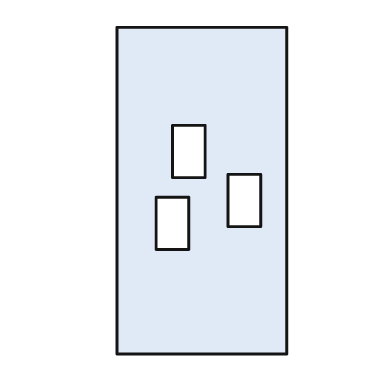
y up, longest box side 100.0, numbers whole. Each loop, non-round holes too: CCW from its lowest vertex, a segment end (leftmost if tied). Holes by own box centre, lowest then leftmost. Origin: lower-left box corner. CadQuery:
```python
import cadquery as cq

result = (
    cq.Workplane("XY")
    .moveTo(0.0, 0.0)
    .lineTo(52.0, 0.0)
    .lineTo(52.0, 100.0)
    .lineTo(0.0, 100.0)
    .close()
    .moveTo(12.0, 32.0)
    .lineTo(22.0, 32.0)
    .lineTo(22.0, 48.0)
    .lineTo(12.0, 48.0)
    .close()
    .moveTo(34.0, 39.0)
    .lineTo(44.0, 39.0)
    .lineTo(44.0, 55.0)
    .lineTo(34.0, 55.0)
    .close()
    .moveTo(17.0, 54.0)
    .lineTo(27.0, 54.0)
    .lineTo(27.0, 70.0)
    .lineTo(17.0, 70.0)
    .close()
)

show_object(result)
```